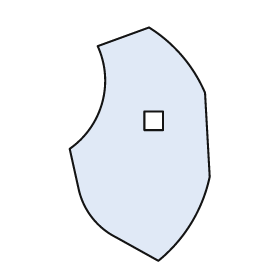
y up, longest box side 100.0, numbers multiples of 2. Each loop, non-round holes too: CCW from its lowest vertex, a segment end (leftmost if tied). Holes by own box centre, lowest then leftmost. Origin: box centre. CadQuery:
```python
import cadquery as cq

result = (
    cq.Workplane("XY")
    .moveTo(8.0, -50.0)
    .threePointArc((22.0, -34.0), (30.0, -14.0))
    .lineTo(28.0, 22.0)
    .threePointArc((18.0, 38.0), (4.0, 50.0))
    .lineTo(-18.0, 42.0)
    .threePointArc((-16.0, 18.0), (-30.0, -2.0))
    .lineTo(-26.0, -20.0)
    .threePointArc((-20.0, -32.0), (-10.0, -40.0))
    .close()
    .moveTo(2.0, 6.0)
    .lineTo(10.0, 6.0)
    .lineTo(10.0, 14.0)
    .lineTo(2.0, 14.0)
    .close()
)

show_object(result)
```